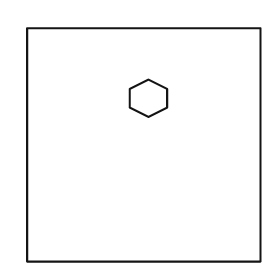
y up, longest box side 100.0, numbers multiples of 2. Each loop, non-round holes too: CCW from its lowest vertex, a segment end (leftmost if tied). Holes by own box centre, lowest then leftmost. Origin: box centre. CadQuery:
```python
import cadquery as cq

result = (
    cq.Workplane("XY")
    .moveTo(-50.0, -50.0)
    .lineTo(50.0, -50.0)
    .lineTo(50.0, 50.0)
    .lineTo(-50.0, 50.0)
    .close()
    .moveTo(2.0, 12.0)
    .lineTo(10.0, 16.0)
    .lineTo(10.0, 24.0)
    .lineTo(2.0, 28.0)
    .lineTo(-6.0, 24.0)
    .lineTo(-6.0, 16.0)
    .close()
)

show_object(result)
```